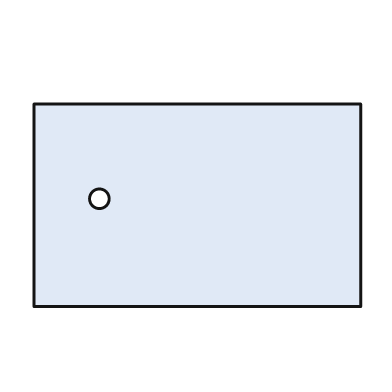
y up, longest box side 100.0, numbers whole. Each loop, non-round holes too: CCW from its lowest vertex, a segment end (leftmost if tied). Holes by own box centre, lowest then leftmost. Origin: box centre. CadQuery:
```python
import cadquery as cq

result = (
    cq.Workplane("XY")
    .moveTo(-50.0, -31.0)
    .lineTo(50.0, -31.0)
    .lineTo(50.0, 31.0)
    .lineTo(-50.0, 31.0)
    .close()
    .moveTo(-30.0, 2.0)
    .circle(3.0)
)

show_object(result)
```